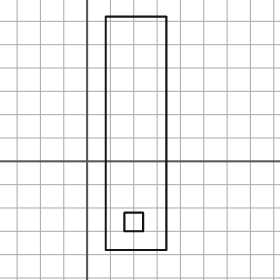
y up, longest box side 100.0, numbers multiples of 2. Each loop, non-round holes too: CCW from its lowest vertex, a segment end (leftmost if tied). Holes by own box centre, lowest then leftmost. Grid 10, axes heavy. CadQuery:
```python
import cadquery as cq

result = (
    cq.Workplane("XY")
    .moveTo(8.0, -38.0)
    .lineTo(34.0, -38.0)
    .lineTo(34.0, 62.0)
    .lineTo(8.0, 62.0)
    .close()
    .moveTo(16.0, -30.0)
    .lineTo(24.0, -30.0)
    .lineTo(24.0, -22.0)
    .lineTo(16.0, -22.0)
    .close()
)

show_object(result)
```